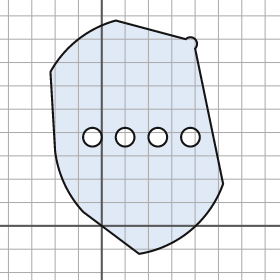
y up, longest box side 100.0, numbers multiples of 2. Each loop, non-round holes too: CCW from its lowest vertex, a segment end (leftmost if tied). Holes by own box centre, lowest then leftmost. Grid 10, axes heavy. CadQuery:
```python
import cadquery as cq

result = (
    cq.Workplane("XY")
    .moveTo(16.0, -12.0)
    .threePointArc((38.0, -2.0), (52.0, 18.0))
    .lineTo(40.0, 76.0)
    .threePointArc((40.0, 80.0), (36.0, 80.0))
    .lineTo(6.0, 88.0)
    .threePointArc((-10.0, 80.0), (-22.0, 66.0))
    .lineTo(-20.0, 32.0)
    .threePointArc((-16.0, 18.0), (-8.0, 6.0))
    .close()
    .moveTo(-4.0, 38.0)
    .circle(4.0)
    .moveTo(10.0, 38.0)
    .circle(4.0)
    .moveTo(24.0, 38.0)
    .circle(4.0)
    .moveTo(38.0, 38.0)
    .circle(4.0)
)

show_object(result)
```